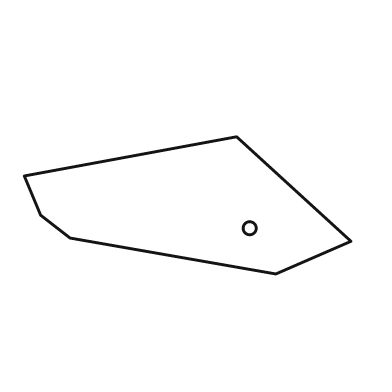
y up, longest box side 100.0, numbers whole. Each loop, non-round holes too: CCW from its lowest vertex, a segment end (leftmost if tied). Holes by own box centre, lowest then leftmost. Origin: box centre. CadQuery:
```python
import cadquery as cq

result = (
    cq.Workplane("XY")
    .moveTo(27.0, -21.0)
    .lineTo(50.0, -11.0)
    .lineTo(15.0, 21.0)
    .lineTo(-50.0, 9.0)
    .lineTo(-45.0, -3.0)
    .lineTo(-36.0, -10.0)
    .close()
    .moveTo(19.0, -7.0)
    .circle(2.0)
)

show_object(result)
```